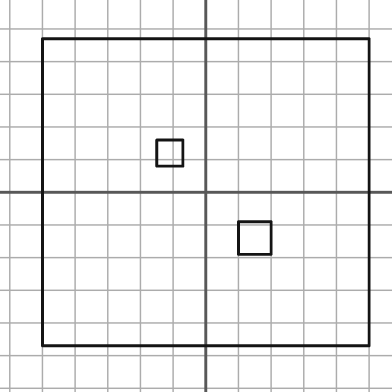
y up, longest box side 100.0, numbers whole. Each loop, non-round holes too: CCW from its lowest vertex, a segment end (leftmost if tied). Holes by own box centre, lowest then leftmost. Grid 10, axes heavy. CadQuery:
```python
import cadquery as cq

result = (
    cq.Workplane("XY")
    .moveTo(-50.0, -47.0)
    .lineTo(50.0, -47.0)
    .lineTo(50.0, 47.0)
    .lineTo(-50.0, 47.0)
    .close()
    .moveTo(10.0, -19.0)
    .lineTo(20.0, -19.0)
    .lineTo(20.0, -9.0)
    .lineTo(10.0, -9.0)
    .close()
    .moveTo(-15.0, 8.0)
    .lineTo(-7.0, 8.0)
    .lineTo(-7.0, 16.0)
    .lineTo(-15.0, 16.0)
    .close()
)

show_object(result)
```